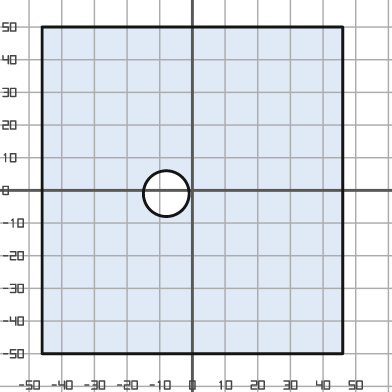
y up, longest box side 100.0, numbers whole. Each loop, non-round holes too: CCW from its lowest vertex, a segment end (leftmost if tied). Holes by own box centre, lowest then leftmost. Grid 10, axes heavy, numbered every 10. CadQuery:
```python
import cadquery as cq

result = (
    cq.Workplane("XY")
    .moveTo(-46.0, -50.0)
    .lineTo(46.0, -50.0)
    .lineTo(46.0, 50.0)
    .lineTo(-46.0, 50.0)
    .close()
    .moveTo(-8.0, -1.0)
    .circle(7.0)
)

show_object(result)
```